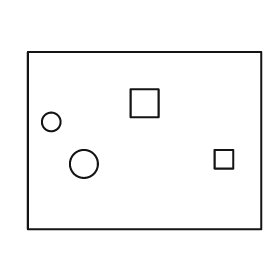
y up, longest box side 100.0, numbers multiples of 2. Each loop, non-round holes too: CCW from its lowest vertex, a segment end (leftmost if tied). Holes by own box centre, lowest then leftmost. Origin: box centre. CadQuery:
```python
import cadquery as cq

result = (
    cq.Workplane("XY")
    .moveTo(-50.0, -38.0)
    .lineTo(50.0, -38.0)
    .lineTo(50.0, 38.0)
    .lineTo(-50.0, 38.0)
    .close()
    .moveTo(-26.0, -10.0)
    .circle(6.0)
    .moveTo(30.0, -12.0)
    .lineTo(38.0, -12.0)
    .lineTo(38.0, -4.0)
    .lineTo(30.0, -4.0)
    .close()
    .moveTo(-40.0, 8.0)
    .circle(4.0)
    .moveTo(-6.0, 10.0)
    .lineTo(6.0, 10.0)
    .lineTo(6.0, 22.0)
    .lineTo(-6.0, 22.0)
    .close()
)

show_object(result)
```